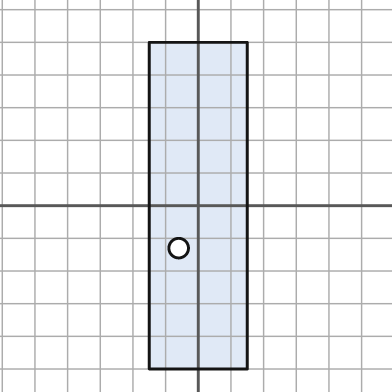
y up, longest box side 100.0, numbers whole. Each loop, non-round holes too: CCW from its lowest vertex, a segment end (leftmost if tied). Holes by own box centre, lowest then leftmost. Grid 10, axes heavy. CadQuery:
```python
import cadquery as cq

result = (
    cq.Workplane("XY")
    .moveTo(-15.0, -50.0)
    .lineTo(15.0, -50.0)
    .lineTo(15.0, 50.0)
    .lineTo(-15.0, 50.0)
    .close()
    .moveTo(-6.0, -13.0)
    .circle(3.0)
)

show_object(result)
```